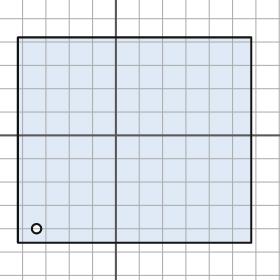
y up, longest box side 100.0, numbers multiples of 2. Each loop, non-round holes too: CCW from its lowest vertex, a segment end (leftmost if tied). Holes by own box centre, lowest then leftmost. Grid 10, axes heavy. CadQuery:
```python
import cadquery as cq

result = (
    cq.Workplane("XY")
    .moveTo(-42.0, -46.0)
    .lineTo(58.0, -46.0)
    .lineTo(58.0, 42.0)
    .lineTo(-42.0, 42.0)
    .close()
    .moveTo(-34.0, -40.0)
    .circle(2.0)
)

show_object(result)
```